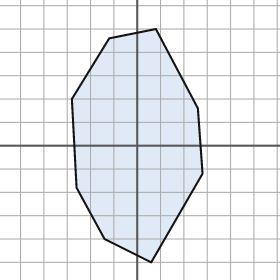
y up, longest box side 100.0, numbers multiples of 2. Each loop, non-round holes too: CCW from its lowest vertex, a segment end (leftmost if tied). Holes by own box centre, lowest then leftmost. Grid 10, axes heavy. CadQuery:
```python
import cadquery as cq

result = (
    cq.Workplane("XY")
    .moveTo(6.0, -50.0)
    .lineTo(28.0, -12.0)
    .lineTo(26.0, 16.0)
    .lineTo(8.0, 50.0)
    .lineTo(-12.0, 46.0)
    .lineTo(-28.0, 20.0)
    .lineTo(-26.0, -18.0)
    .lineTo(-14.0, -40.0)
    .close()
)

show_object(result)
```